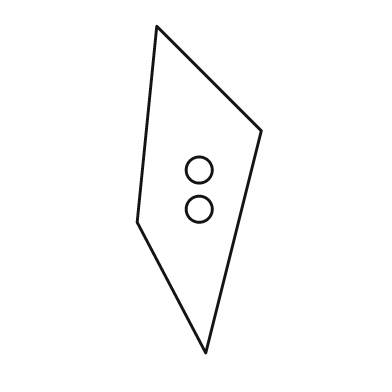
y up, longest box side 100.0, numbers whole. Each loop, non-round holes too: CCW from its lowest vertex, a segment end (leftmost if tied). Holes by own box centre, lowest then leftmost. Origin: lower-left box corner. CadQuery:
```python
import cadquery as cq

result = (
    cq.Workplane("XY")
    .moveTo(21.0, 0.0)
    .lineTo(38.0, 68.0)
    .lineTo(6.0, 100.0)
    .lineTo(0.0, 40.0)
    .close()
    .moveTo(19.0, 44.0)
    .circle(4.0)
    .moveTo(19.0, 56.0)
    .circle(4.0)
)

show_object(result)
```